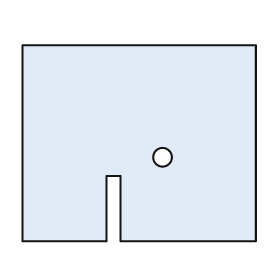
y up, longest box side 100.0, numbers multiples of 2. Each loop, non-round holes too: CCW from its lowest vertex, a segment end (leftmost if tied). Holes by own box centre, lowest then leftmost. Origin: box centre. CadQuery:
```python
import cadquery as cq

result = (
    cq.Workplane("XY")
    .moveTo(-50.0, -42.0)
    .lineTo(-14.0, -42.0)
    .lineTo(-14.0, -14.0)
    .lineTo(-8.0, -14.0)
    .lineTo(-8.0, -42.0)
    .lineTo(50.0, -42.0)
    .lineTo(50.0, 42.0)
    .lineTo(-50.0, 42.0)
    .close()
    .moveTo(10.0, -6.0)
    .circle(4.0)
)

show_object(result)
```